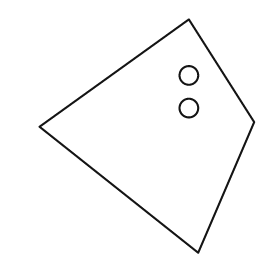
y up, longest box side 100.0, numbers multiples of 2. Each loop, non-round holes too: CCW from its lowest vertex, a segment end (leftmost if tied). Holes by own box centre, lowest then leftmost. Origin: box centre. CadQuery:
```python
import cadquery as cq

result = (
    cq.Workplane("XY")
    .moveTo(22.0, -50.0)
    .lineTo(46.0, 6.0)
    .lineTo(18.0, 50.0)
    .lineTo(-46.0, 4.0)
    .close()
    .moveTo(18.0, 12.0)
    .circle(4.0)
    .moveTo(18.0, 26.0)
    .circle(4.0)
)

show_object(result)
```